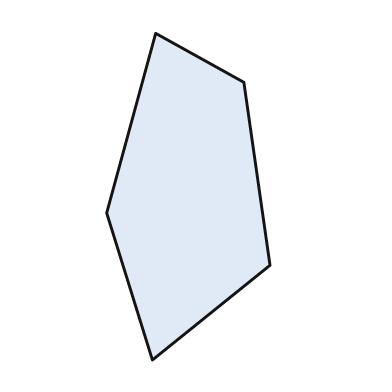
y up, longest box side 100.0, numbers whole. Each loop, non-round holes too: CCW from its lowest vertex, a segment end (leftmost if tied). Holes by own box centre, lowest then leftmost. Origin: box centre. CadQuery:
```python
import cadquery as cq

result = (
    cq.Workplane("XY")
    .moveTo(-11.0, -50.0)
    .lineTo(25.0, -21.0)
    .lineTo(17.0, 35.0)
    .lineTo(-10.0, 50.0)
    .lineTo(-25.0, -5.0)
    .close()
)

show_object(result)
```